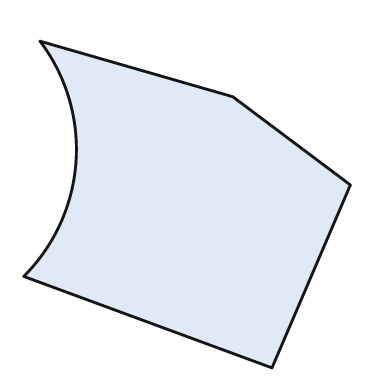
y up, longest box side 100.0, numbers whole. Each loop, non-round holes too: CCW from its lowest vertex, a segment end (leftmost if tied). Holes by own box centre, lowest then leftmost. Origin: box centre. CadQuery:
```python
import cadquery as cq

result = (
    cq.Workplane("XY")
    .moveTo(26.0, -50.0)
    .lineTo(50.0, 6.0)
    .lineTo(14.0, 33.0)
    .lineTo(-45.0, 50.0)
    .threePointArc((-34.0, 13.0), (-50.0, -22.0))
    .close()
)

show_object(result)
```